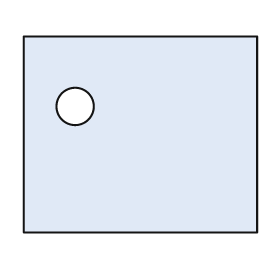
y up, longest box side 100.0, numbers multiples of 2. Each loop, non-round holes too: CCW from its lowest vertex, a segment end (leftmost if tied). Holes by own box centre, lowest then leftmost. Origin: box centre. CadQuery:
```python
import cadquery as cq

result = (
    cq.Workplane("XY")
    .moveTo(-50.0, -42.0)
    .lineTo(50.0, -42.0)
    .lineTo(50.0, 42.0)
    .lineTo(-50.0, 42.0)
    .close()
    .moveTo(-28.0, 12.0)
    .circle(8.0)
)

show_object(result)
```